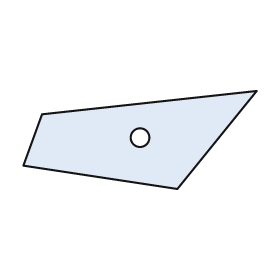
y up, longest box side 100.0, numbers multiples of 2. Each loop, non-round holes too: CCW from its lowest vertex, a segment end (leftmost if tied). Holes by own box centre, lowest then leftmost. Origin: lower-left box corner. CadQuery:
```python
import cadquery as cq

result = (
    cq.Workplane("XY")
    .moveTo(66.0, 0.0)
    .lineTo(100.0, 42.0)
    .lineTo(8.0, 32.0)
    .lineTo(0.0, 10.0)
    .close()
    .moveTo(50.0, 22.0)
    .circle(4.0)
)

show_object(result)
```